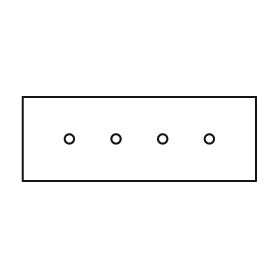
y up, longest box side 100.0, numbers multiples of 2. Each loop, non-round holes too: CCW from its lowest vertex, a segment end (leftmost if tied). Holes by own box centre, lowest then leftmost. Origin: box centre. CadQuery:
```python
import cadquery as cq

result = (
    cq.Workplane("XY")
    .moveTo(-50.0, -18.0)
    .lineTo(50.0, -18.0)
    .lineTo(50.0, 18.0)
    .lineTo(-50.0, 18.0)
    .close()
    .moveTo(-30.0, 0.0)
    .circle(2.0)
    .moveTo(-10.0, 0.0)
    .circle(2.0)
    .moveTo(10.0, 0.0)
    .circle(2.0)
    .moveTo(30.0, 0.0)
    .circle(2.0)
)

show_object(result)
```